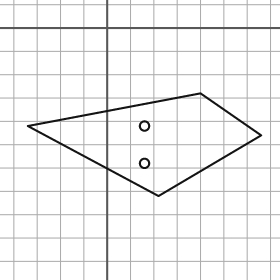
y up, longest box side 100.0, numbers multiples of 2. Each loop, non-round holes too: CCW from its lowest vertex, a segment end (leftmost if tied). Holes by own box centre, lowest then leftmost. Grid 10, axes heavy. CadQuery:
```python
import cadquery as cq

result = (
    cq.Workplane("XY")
    .moveTo(22.0, -72.0)
    .lineTo(66.0, -46.0)
    .lineTo(40.0, -28.0)
    .lineTo(-34.0, -42.0)
    .close()
    .moveTo(16.0, -58.0)
    .circle(2.0)
    .moveTo(16.0, -42.0)
    .circle(2.0)
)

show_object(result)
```